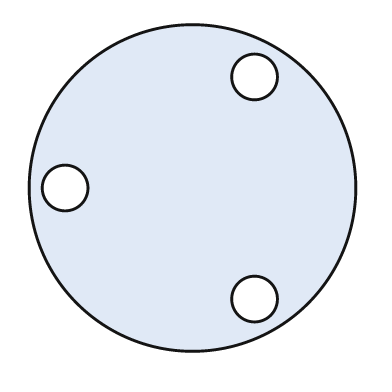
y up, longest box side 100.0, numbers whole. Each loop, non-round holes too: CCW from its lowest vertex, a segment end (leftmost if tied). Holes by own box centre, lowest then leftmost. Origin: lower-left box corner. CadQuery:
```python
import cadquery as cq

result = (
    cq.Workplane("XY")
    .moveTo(50.0, 50.0)
    .circle(50.0)
    .moveTo(69.0, 16.0)
    .circle(7.0)
    .moveTo(11.0, 50.0)
    .circle(7.0)
    .moveTo(69.0, 84.0)
    .circle(7.0)
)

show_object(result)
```